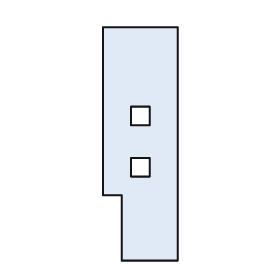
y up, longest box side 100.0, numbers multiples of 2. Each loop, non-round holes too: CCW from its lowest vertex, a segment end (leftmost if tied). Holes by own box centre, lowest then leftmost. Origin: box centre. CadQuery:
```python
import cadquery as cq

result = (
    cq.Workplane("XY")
    .moveTo(-8.0, -50.0)
    .lineTo(16.0, -50.0)
    .lineTo(16.0, 50.0)
    .lineTo(-16.0, 50.0)
    .lineTo(-16.0, -22.0)
    .lineTo(-8.0, -22.0)
    .close()
    .moveTo(-4.0, -14.0)
    .lineTo(4.0, -14.0)
    .lineTo(4.0, -6.0)
    .lineTo(-4.0, -6.0)
    .close()
    .moveTo(-4.0, 8.0)
    .lineTo(4.0, 8.0)
    .lineTo(4.0, 16.0)
    .lineTo(-4.0, 16.0)
    .close()
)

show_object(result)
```